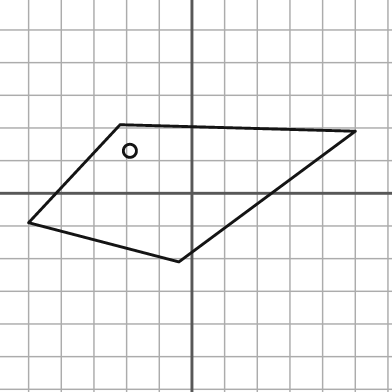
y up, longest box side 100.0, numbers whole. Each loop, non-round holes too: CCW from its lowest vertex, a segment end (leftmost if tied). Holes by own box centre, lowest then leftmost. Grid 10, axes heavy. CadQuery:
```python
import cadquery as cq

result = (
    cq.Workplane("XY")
    .moveTo(-4.0, -21.0)
    .lineTo(50.0, 19.0)
    .lineTo(-22.0, 21.0)
    .lineTo(-50.0, -9.0)
    .close()
    .moveTo(-19.0, 13.0)
    .circle(2.0)
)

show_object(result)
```